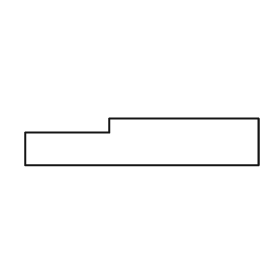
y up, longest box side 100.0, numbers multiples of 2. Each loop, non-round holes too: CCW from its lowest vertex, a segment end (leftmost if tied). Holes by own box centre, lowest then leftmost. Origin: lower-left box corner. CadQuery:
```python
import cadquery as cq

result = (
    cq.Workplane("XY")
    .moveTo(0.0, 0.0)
    .lineTo(100.0, 0.0)
    .lineTo(100.0, 20.0)
    .lineTo(36.0, 20.0)
    .lineTo(36.0, 14.0)
    .lineTo(0.0, 14.0)
    .close()
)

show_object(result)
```